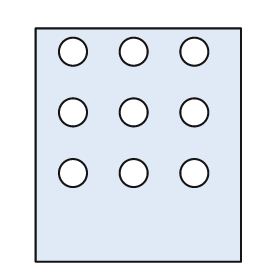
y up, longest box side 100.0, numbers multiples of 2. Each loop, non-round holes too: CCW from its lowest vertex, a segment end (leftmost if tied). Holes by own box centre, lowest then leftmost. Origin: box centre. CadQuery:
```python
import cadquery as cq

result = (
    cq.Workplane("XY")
    .moveTo(-44.0, -50.0)
    .lineTo(44.0, -50.0)
    .lineTo(44.0, 50.0)
    .lineTo(-44.0, 50.0)
    .close()
    .moveTo(-28.0, -12.0)
    .circle(6.0)
    .moveTo(-2.0, -12.0)
    .circle(6.0)
    .moveTo(24.0, -12.0)
    .circle(6.0)
    .moveTo(-28.0, 14.0)
    .circle(6.0)
    .moveTo(-2.0, 14.0)
    .circle(6.0)
    .moveTo(24.0, 14.0)
    .circle(6.0)
    .moveTo(-28.0, 40.0)
    .circle(6.0)
    .moveTo(-2.0, 40.0)
    .circle(6.0)
    .moveTo(24.0, 40.0)
    .circle(6.0)
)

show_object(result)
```